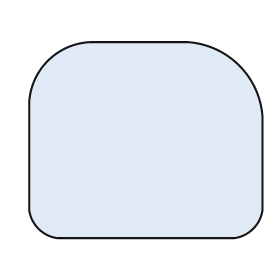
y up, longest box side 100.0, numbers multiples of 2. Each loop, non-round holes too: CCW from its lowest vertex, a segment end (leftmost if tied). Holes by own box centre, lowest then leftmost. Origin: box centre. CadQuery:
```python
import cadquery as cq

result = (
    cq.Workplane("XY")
    .moveTo(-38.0, -42.0)
    .lineTo(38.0, -42.0)
    .threePointArc((46.0, -38.0), (50.0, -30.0))
    .lineTo(50.0, 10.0)
    .threePointArc((40.0, 32.0), (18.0, 42.0))
    .lineTo(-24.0, 42.0)
    .threePointArc((-42.0, 34.0), (-50.0, 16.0))
    .lineTo(-50.0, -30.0)
    .threePointArc((-46.0, -38.0), (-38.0, -42.0))
    .close()
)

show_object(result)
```